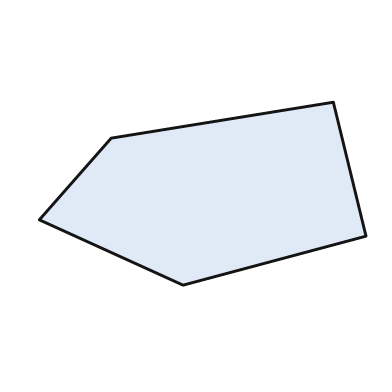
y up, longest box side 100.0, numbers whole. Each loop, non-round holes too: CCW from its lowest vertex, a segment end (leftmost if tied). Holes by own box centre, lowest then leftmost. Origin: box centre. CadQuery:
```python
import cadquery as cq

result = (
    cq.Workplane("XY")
    .moveTo(-6.0, -28.0)
    .lineTo(50.0, -13.0)
    .lineTo(40.0, 28.0)
    .lineTo(-28.0, 17.0)
    .lineTo(-50.0, -8.0)
    .close()
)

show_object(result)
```